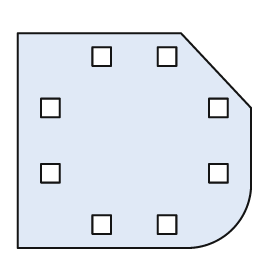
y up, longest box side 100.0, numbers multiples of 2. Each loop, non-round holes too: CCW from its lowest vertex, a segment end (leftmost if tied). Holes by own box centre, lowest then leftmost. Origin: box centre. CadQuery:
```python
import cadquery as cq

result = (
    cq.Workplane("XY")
    .moveTo(-50.0, -46.0)
    .lineTo(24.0, -46.0)
    .threePointArc((42.0, -38.0), (50.0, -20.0))
    .lineTo(50.0, 14.0)
    .lineTo(20.0, 46.0)
    .lineTo(-50.0, 46.0)
    .close()
    .moveTo(-18.0, -40.0)
    .lineTo(-10.0, -40.0)
    .lineTo(-10.0, -32.0)
    .lineTo(-18.0, -32.0)
    .close()
    .moveTo(10.0, -40.0)
    .lineTo(18.0, -40.0)
    .lineTo(18.0, -32.0)
    .lineTo(10.0, -32.0)
    .close()
    .moveTo(-40.0, -18.0)
    .lineTo(-32.0, -18.0)
    .lineTo(-32.0, -10.0)
    .lineTo(-40.0, -10.0)
    .close()
    .moveTo(32.0, -18.0)
    .lineTo(40.0, -18.0)
    .lineTo(40.0, -10.0)
    .lineTo(32.0, -10.0)
    .close()
    .moveTo(-40.0, 10.0)
    .lineTo(-32.0, 10.0)
    .lineTo(-32.0, 18.0)
    .lineTo(-40.0, 18.0)
    .close()
    .moveTo(32.0, 10.0)
    .lineTo(40.0, 10.0)
    .lineTo(40.0, 18.0)
    .lineTo(32.0, 18.0)
    .close()
    .moveTo(-18.0, 32.0)
    .lineTo(-10.0, 32.0)
    .lineTo(-10.0, 40.0)
    .lineTo(-18.0, 40.0)
    .close()
    .moveTo(10.0, 32.0)
    .lineTo(18.0, 32.0)
    .lineTo(18.0, 40.0)
    .lineTo(10.0, 40.0)
    .close()
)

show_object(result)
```